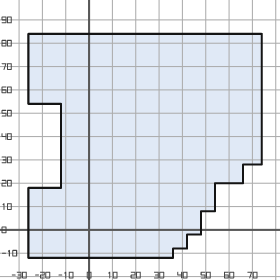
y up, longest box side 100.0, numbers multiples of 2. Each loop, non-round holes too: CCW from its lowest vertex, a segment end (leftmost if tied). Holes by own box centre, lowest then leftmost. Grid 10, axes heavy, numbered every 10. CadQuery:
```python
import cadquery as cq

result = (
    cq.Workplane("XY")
    .moveTo(-26.0, -12.0)
    .lineTo(36.0, -12.0)
    .lineTo(36.0, -8.0)
    .lineTo(42.0, -8.0)
    .lineTo(42.0, -2.0)
    .lineTo(48.0, -2.0)
    .lineTo(48.0, 8.0)
    .lineTo(54.0, 8.0)
    .lineTo(54.0, 20.0)
    .lineTo(66.0, 20.0)
    .lineTo(66.0, 28.0)
    .lineTo(74.0, 28.0)
    .lineTo(74.0, 84.0)
    .lineTo(-26.0, 84.0)
    .lineTo(-26.0, 54.0)
    .lineTo(-12.0, 54.0)
    .lineTo(-12.0, 18.0)
    .lineTo(-26.0, 18.0)
    .close()
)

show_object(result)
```